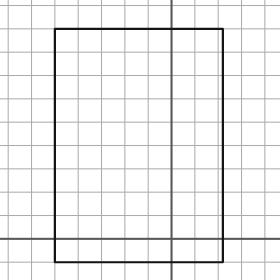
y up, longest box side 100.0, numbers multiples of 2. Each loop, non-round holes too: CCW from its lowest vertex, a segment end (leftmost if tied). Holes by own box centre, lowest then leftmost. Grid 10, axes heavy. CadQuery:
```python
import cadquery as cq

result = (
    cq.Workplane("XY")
    .moveTo(-50.0, -10.0)
    .lineTo(22.0, -10.0)
    .lineTo(22.0, 90.0)
    .lineTo(-50.0, 90.0)
    .close()
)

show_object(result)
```